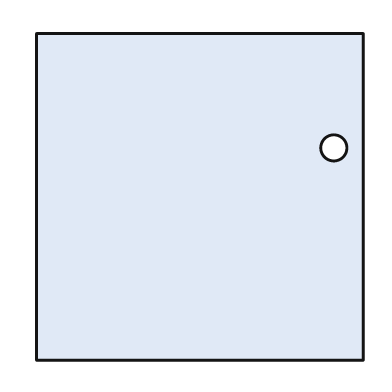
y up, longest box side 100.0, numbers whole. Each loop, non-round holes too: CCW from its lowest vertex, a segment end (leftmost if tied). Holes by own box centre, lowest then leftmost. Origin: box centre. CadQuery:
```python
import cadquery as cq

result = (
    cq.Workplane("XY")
    .moveTo(-50.0, -50.0)
    .lineTo(50.0, -50.0)
    .lineTo(50.0, 50.0)
    .lineTo(-50.0, 50.0)
    .close()
    .moveTo(41.0, 15.0)
    .circle(4.0)
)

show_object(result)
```